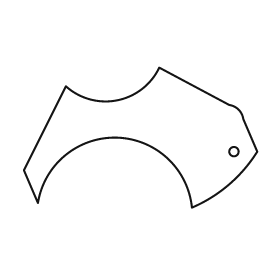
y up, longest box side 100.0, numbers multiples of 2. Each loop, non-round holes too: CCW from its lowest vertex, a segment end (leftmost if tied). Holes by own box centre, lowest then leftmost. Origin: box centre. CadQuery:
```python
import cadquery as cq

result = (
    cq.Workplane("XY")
    .moveTo(22.0, -30.0)
    .threePointArc((38.0, -20.0), (50.0, -6.0))
    .lineTo(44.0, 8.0)
    .threePointArc((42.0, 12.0), (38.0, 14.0))
    .lineTo(8.0, 30.0)
    .threePointArc((-10.0, 16.0), (-32.0, 22.0))
    .lineTo(-50.0, -14.0)
    .lineTo(-44.0, -28.0)
    .threePointArc((-10.0, 0.0), (22.0, -30.0))
    .close()
    .moveTo(40.0, -6.0)
    .circle(2.0)
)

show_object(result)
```